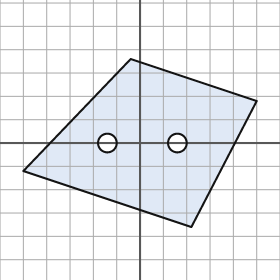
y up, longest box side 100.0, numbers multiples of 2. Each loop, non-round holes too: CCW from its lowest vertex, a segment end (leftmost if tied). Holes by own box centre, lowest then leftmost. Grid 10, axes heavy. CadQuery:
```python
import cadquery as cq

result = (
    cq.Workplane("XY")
    .moveTo(22.0, -36.0)
    .lineTo(50.0, 18.0)
    .lineTo(-4.0, 36.0)
    .lineTo(-50.0, -12.0)
    .close()
    .moveTo(-14.0, 0.0)
    .circle(4.0)
    .moveTo(16.0, 0.0)
    .circle(4.0)
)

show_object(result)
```